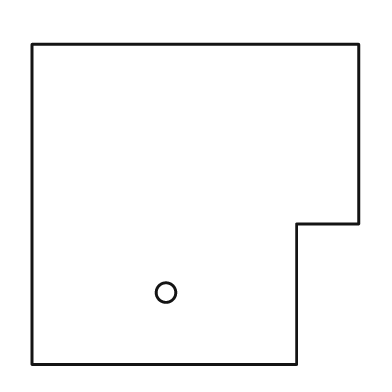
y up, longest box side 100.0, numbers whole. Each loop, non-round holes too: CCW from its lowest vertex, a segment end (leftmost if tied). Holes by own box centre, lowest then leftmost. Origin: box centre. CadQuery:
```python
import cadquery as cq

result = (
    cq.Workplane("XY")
    .moveTo(-50.0, -49.0)
    .lineTo(31.0, -49.0)
    .lineTo(31.0, -6.0)
    .lineTo(50.0, -6.0)
    .lineTo(50.0, 49.0)
    .lineTo(-50.0, 49.0)
    .close()
    .moveTo(-9.0, -27.0)
    .circle(3.0)
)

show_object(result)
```